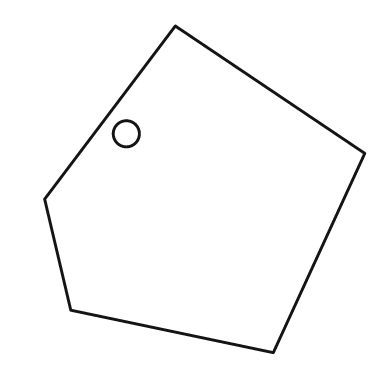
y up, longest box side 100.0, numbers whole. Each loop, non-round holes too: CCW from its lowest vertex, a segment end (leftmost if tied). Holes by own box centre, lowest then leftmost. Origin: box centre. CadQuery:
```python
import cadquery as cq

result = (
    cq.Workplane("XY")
    .moveTo(21.0, -50.0)
    .lineTo(49.0, 11.0)
    .lineTo(-9.0, 50.0)
    .lineTo(-49.0, -3.0)
    .lineTo(-41.0, -37.0)
    .close()
    .moveTo(-24.0, 17.0)
    .circle(4.0)
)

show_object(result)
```